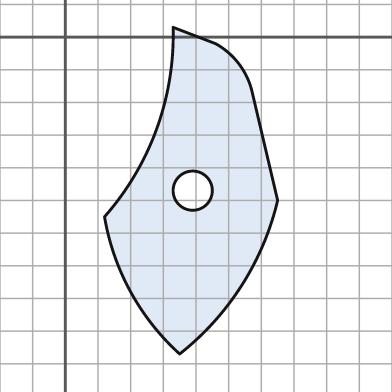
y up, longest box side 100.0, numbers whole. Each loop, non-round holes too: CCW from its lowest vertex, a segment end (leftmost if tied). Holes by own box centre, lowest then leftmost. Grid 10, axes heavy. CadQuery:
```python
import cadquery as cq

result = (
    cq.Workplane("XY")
    .moveTo(35.0, -97.0)
    .threePointArc((54.0, -76.0), (65.0, -50.0))
    .lineTo(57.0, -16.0)
    .threePointArc((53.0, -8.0), (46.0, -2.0))
    .lineTo(33.0, 3.0)
    .threePointArc((28.0, -28.0), (12.0, -55.0))
    .threePointArc((20.0, -78.0), (35.0, -97.0))
    .close()
    .moveTo(39.0, -47.0)
    .circle(6.0)
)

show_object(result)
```